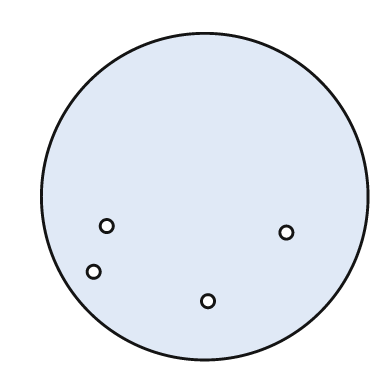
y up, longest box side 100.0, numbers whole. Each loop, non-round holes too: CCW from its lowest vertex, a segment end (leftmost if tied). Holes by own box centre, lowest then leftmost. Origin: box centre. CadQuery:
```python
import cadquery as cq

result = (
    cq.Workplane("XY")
    .moveTo(0.0, 0.0)
    .circle(50.0)
    .moveTo(1.0, -32.0)
    .circle(2.0)
    .moveTo(-34.0, -23.0)
    .circle(2.0)
    .moveTo(25.0, -11.0)
    .circle(2.0)
    .moveTo(-30.0, -9.0)
    .circle(2.0)
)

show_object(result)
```